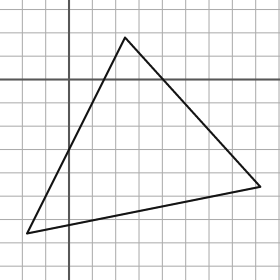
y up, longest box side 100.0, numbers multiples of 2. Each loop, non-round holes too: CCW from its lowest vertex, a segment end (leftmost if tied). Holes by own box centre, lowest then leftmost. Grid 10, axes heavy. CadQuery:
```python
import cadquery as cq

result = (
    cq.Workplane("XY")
    .moveTo(-18.0, -66.0)
    .lineTo(82.0, -46.0)
    .lineTo(24.0, 18.0)
    .close()
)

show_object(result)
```